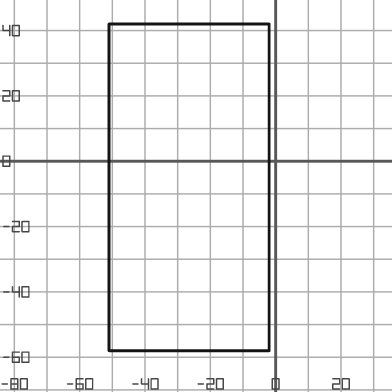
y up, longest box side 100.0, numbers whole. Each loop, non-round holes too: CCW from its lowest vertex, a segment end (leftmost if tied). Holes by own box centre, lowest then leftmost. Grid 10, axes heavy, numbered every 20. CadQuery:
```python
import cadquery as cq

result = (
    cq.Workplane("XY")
    .moveTo(-51.0, -58.0)
    .lineTo(-2.0, -58.0)
    .lineTo(-2.0, 42.0)
    .lineTo(-51.0, 42.0)
    .close()
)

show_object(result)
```